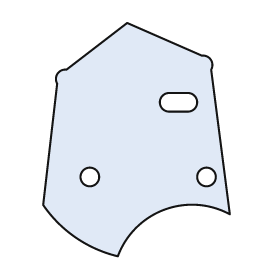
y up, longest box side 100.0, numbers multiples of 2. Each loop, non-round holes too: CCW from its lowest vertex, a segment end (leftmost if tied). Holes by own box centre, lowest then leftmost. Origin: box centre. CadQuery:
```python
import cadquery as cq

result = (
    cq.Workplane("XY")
    .moveTo(-8.0, -50.0)
    .threePointArc((12.0, -30.0), (40.0, -32.0))
    .lineTo(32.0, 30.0)
    .threePointArc((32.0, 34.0), (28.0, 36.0))
    .lineTo(-4.0, 50.0)
    .lineTo(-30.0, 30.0)
    .threePointArc((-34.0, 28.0), (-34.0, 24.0))
    .lineTo(-40.0, -28.0)
    .threePointArc((-26.0, -42.0), (-8.0, -50.0))
    .close()
    .moveTo(-20.0, -16.0)
    .circle(4.0)
    .moveTo(30.0, -16.0)
    .circle(4.0)
    .moveTo(14.0, 12.0)
    .lineTo(22.0, 12.0)
    .threePointArc((26.0, 16.0), (22.0, 20.0))
    .lineTo(14.0, 20.0)
    .threePointArc((10.0, 16.0), (14.0, 12.0))
    .close()
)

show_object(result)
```